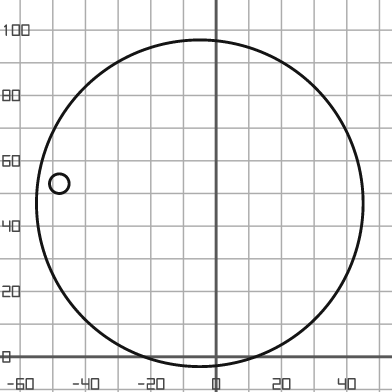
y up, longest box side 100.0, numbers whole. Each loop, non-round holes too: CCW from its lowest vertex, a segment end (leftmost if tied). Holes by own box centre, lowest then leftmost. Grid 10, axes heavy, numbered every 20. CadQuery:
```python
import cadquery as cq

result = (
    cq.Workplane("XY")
    .moveTo(-5.0, 47.0)
    .circle(50.0)
    .moveTo(-48.0, 53.0)
    .circle(3.0)
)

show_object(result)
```